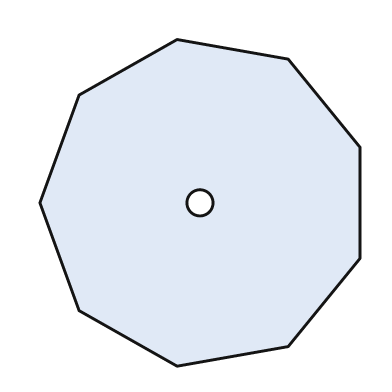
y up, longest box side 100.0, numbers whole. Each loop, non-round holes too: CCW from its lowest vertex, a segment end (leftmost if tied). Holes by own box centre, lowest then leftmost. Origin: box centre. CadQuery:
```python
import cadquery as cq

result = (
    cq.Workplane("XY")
    .moveTo(-7.0, -50.0)
    .lineTo(27.0, -44.0)
    .lineTo(49.0, -17.0)
    .lineTo(49.0, 17.0)
    .lineTo(27.0, 44.0)
    .lineTo(-7.0, 50.0)
    .lineTo(-37.0, 33.0)
    .lineTo(-49.0, 0.0)
    .lineTo(-37.0, -33.0)
    .close()
    .moveTo(0.0, 0.0)
    .circle(4.0)
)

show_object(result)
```